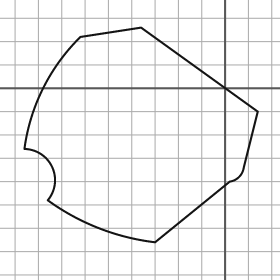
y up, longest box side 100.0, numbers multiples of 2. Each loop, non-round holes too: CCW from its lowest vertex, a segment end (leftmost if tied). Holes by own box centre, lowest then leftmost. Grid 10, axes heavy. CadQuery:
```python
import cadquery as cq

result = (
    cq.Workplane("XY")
    .moveTo(-30.0, -66.0)
    .lineTo(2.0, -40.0)
    .threePointArc((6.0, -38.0), (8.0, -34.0))
    .lineTo(14.0, -10.0)
    .lineTo(-36.0, 26.0)
    .lineTo(-62.0, 22.0)
    .threePointArc((-78.0, 0.0), (-86.0, -26.0))
    .threePointArc((-74.0, -34.0), (-76.0, -48.0))
    .threePointArc((-54.0, -60.0), (-30.0, -66.0))
    .close()
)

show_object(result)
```